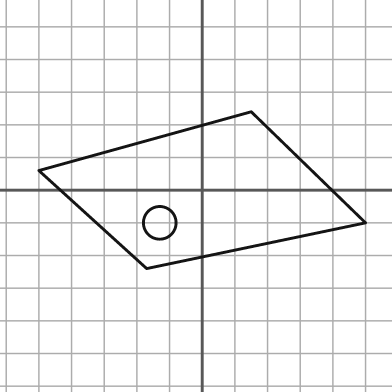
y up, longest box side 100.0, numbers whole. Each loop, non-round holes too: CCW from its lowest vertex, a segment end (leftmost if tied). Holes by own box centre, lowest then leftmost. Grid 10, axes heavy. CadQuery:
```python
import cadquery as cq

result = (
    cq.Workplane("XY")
    .moveTo(-17.0, -24.0)
    .lineTo(50.0, -10.0)
    .lineTo(15.0, 24.0)
    .lineTo(-50.0, 6.0)
    .close()
    .moveTo(-13.0, -10.0)
    .circle(5.0)
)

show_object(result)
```